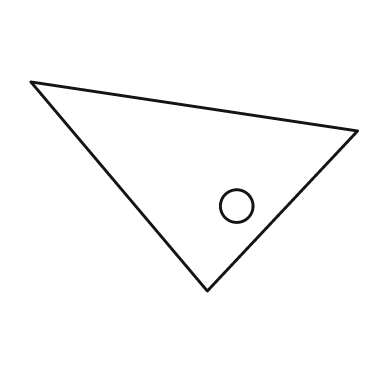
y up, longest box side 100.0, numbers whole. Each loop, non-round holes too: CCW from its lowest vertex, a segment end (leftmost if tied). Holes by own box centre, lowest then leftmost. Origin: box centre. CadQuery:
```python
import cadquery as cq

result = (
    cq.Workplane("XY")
    .moveTo(4.0, -32.0)
    .lineTo(50.0, 17.0)
    .lineTo(-50.0, 32.0)
    .close()
    .moveTo(13.0, -6.0)
    .circle(5.0)
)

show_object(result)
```